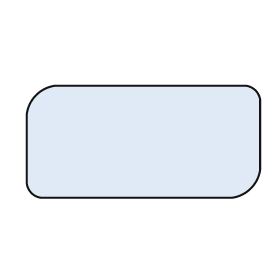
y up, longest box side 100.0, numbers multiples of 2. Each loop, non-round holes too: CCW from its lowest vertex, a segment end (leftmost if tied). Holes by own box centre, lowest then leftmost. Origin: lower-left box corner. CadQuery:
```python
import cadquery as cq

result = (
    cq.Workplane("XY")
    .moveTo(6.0, 0.0)
    .lineTo(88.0, 0.0)
    .threePointArc((96.0, 4.0), (100.0, 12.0))
    .lineTo(100.0, 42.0)
    .threePointArc((98.0, 46.0), (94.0, 48.0))
    .lineTo(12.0, 48.0)
    .threePointArc((4.0, 44.0), (0.0, 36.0))
    .lineTo(0.0, 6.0)
    .threePointArc((2.0, 2.0), (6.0, 0.0))
    .close()
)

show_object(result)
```